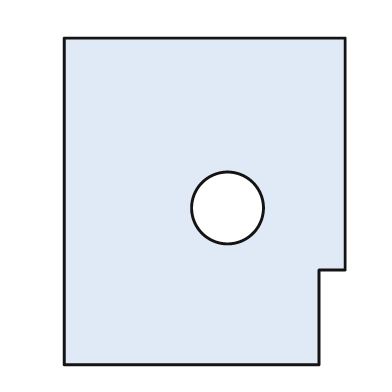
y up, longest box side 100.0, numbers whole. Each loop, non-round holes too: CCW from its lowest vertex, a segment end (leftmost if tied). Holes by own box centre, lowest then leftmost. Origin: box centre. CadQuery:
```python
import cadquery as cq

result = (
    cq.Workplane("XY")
    .moveTo(-43.0, -50.0)
    .lineTo(35.0, -50.0)
    .lineTo(35.0, -21.0)
    .lineTo(43.0, -21.0)
    .lineTo(43.0, 50.0)
    .lineTo(-43.0, 50.0)
    .close()
    .moveTo(7.0, -2.0)
    .circle(11.0)
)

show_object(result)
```